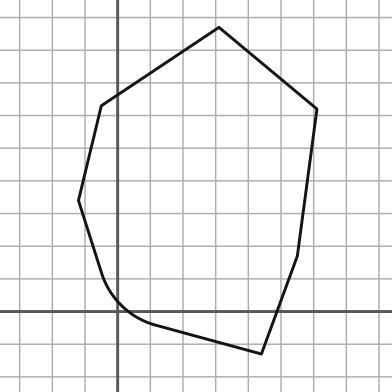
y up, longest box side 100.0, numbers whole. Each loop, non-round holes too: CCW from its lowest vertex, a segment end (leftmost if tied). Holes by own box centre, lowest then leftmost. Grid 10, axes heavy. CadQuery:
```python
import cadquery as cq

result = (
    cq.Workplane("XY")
    .moveTo(44.0, -13.0)
    .lineTo(55.0, 17.0)
    .lineTo(61.0, 62.0)
    .lineTo(31.0, 87.0)
    .lineTo(-5.0, 63.0)
    .lineTo(-12.0, 34.0)
    .lineTo(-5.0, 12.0)
    .threePointArc((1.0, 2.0), (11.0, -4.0))
    .close()
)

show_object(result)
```